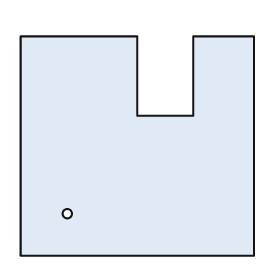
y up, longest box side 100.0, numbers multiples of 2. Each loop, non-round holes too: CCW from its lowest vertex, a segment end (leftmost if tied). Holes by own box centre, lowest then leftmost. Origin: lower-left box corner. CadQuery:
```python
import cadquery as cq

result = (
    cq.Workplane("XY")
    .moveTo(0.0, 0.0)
    .lineTo(100.0, 0.0)
    .lineTo(100.0, 94.0)
    .lineTo(74.0, 94.0)
    .lineTo(74.0, 60.0)
    .lineTo(50.0, 60.0)
    .lineTo(50.0, 94.0)
    .lineTo(0.0, 94.0)
    .close()
    .moveTo(20.0, 18.0)
    .circle(2.0)
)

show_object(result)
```